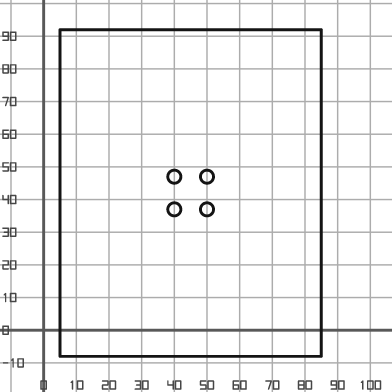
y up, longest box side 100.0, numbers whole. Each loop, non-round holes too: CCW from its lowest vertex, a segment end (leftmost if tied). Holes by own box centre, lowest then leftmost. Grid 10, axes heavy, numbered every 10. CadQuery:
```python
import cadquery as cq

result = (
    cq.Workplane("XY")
    .moveTo(5.0, -8.0)
    .lineTo(85.0, -8.0)
    .lineTo(85.0, 92.0)
    .lineTo(5.0, 92.0)
    .close()
    .moveTo(40.0, 37.0)
    .circle(2.0)
    .moveTo(50.0, 37.0)
    .circle(2.0)
    .moveTo(40.0, 47.0)
    .circle(2.0)
    .moveTo(50.0, 47.0)
    .circle(2.0)
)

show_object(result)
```